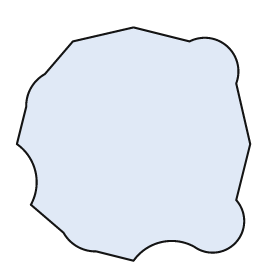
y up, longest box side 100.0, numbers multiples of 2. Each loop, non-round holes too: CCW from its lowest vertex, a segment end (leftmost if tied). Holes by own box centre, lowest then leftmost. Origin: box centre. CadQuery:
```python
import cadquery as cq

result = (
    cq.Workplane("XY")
    .moveTo(0.0, -50.0)
    .threePointArc((12.0, -42.0), (26.0, -44.0))
    .threePointArc((44.0, -42.0), (44.0, -24.0))
    .lineTo(50.0, 0.0)
    .lineTo(44.0, 26.0)
    .threePointArc((40.0, 42.0), (24.0, 44.0))
    .lineTo(0.0, 50.0)
    .lineTo(-26.0, 44.0)
    .lineTo(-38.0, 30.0)
    .threePointArc((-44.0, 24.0), (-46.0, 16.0))
    .lineTo(-50.0, 0.0)
    .threePointArc((-42.0, -12.0), (-44.0, -26.0))
    .lineTo(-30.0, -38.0)
    .threePointArc((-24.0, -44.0), (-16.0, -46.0))
    .close()
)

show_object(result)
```